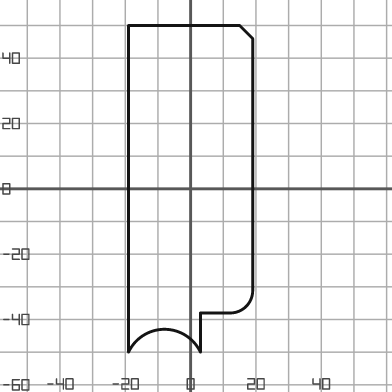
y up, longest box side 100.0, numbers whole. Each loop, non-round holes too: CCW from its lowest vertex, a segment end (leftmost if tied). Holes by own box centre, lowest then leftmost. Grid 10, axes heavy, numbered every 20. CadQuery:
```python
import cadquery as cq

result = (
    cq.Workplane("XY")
    .moveTo(-19.0, -50.0)
    .threePointArc((-8.0, -43.0), (3.0, -50.0))
    .lineTo(3.0, -38.0)
    .lineTo(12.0, -38.0)
    .threePointArc((17.0, -36.0), (19.0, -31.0))
    .lineTo(19.0, 46.0)
    .lineTo(15.0, 50.0)
    .lineTo(-19.0, 50.0)
    .close()
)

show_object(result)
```